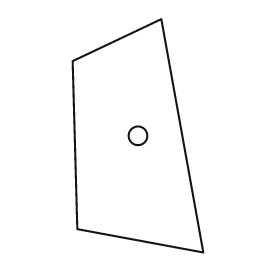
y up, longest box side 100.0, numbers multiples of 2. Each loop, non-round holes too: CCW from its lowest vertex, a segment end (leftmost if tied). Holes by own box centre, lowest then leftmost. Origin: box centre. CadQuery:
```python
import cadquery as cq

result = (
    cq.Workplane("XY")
    .moveTo(28.0, -50.0)
    .lineTo(10.0, 50.0)
    .lineTo(-28.0, 32.0)
    .lineTo(-26.0, -40.0)
    .close()
    .moveTo(0.0, 0.0)
    .circle(4.0)
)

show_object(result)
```